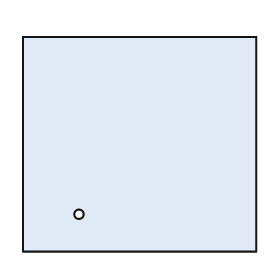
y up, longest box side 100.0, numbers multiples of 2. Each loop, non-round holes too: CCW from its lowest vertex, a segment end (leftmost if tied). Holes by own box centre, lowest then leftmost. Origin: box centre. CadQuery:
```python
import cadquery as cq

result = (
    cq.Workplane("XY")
    .moveTo(-50.0, -46.0)
    .lineTo(50.0, -46.0)
    .lineTo(50.0, 46.0)
    .lineTo(-50.0, 46.0)
    .close()
    .moveTo(-26.0, -30.0)
    .circle(2.0)
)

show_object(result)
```